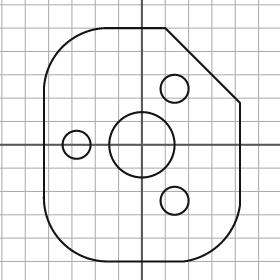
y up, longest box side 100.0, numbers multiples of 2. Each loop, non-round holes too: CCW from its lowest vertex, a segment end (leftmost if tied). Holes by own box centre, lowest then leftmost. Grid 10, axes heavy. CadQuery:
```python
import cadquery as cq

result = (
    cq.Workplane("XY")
    .moveTo(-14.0, -50.0)
    .lineTo(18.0, -50.0)
    .threePointArc((34.0, -42.0), (42.0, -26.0))
    .lineTo(42.0, 18.0)
    .lineTo(10.0, 50.0)
    .lineTo(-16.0, 50.0)
    .threePointArc((-34.0, 42.0), (-42.0, 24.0))
    .lineTo(-42.0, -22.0)
    .threePointArc((-34.0, -42.0), (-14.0, -50.0))
    .close()
    .moveTo(14.0, -24.0)
    .circle(6.0)
    .moveTo(-28.0, 0.0)
    .circle(6.0)
    .moveTo(0.0, 0.0)
    .circle(14.0)
    .moveTo(14.0, 24.0)
    .circle(6.0)
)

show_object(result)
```